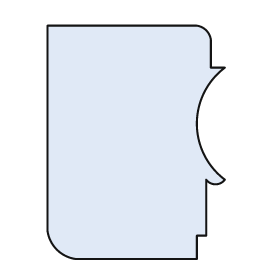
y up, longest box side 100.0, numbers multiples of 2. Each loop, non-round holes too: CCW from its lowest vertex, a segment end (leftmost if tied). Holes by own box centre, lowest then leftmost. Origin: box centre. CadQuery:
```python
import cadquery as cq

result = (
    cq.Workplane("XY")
    .moveTo(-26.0, -50.0)
    .lineTo(26.0, -50.0)
    .lineTo(26.0, -40.0)
    .lineTo(30.0, -40.0)
    .lineTo(30.0, -16.0)
    .threePointArc((34.0, -18.0), (38.0, -16.0))
    .threePointArc((26.0, 8.0), (38.0, 32.0))
    .lineTo(32.0, 32.0)
    .lineTo(32.0, 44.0)
    .threePointArc((30.0, 48.0), (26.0, 50.0))
    .lineTo(-38.0, 50.0)
    .lineTo(-38.0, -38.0)
    .threePointArc((-34.0, -46.0), (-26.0, -50.0))
    .close()
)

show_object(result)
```